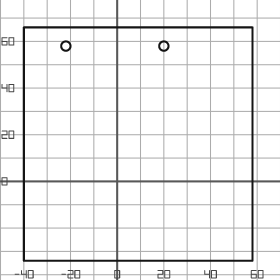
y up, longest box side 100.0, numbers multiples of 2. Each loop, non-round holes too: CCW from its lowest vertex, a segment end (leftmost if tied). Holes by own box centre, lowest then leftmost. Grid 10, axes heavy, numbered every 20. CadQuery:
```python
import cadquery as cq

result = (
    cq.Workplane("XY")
    .moveTo(-40.0, -34.0)
    .lineTo(58.0, -34.0)
    .lineTo(58.0, 66.0)
    .lineTo(-40.0, 66.0)
    .close()
    .moveTo(-22.0, 58.0)
    .circle(2.0)
    .moveTo(20.0, 58.0)
    .circle(2.0)
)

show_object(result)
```